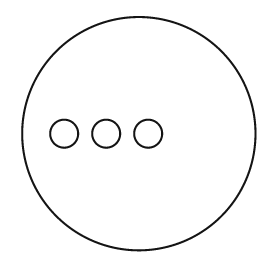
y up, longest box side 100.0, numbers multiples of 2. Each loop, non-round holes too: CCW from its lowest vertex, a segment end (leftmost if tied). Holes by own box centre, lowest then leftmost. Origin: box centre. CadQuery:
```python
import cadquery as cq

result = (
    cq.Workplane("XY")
    .moveTo(0.0, 0.0)
    .circle(50.0)
    .moveTo(-32.0, 0.0)
    .circle(6.0)
    .moveTo(-14.0, 0.0)
    .circle(6.0)
    .moveTo(4.0, 0.0)
    .circle(6.0)
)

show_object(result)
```